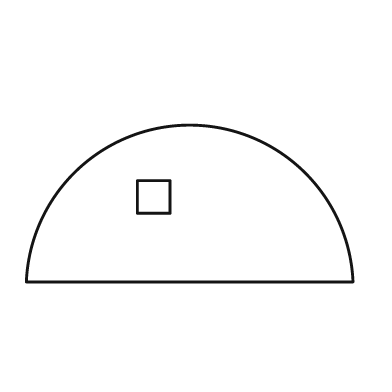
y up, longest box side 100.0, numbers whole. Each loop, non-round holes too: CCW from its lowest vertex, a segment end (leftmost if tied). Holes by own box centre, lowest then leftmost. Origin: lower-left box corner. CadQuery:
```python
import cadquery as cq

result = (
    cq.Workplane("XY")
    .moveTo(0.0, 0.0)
    .lineTo(100.0, 0.0)
    .threePointArc((50.0, 48.0), (0.0, 0.0))
    .close()
    .moveTo(34.0, 21.0)
    .lineTo(44.0, 21.0)
    .lineTo(44.0, 31.0)
    .lineTo(34.0, 31.0)
    .close()
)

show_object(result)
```